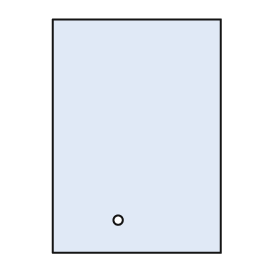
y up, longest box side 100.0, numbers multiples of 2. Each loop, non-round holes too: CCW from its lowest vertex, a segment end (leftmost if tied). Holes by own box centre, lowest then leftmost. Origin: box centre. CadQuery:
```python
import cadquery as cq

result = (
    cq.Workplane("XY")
    .moveTo(-36.0, -50.0)
    .lineTo(36.0, -50.0)
    .lineTo(36.0, 50.0)
    .lineTo(-36.0, 50.0)
    .close()
    .moveTo(-8.0, -36.0)
    .circle(2.0)
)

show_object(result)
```